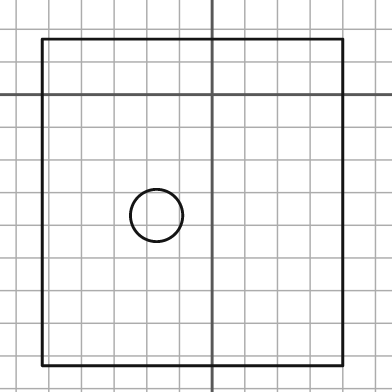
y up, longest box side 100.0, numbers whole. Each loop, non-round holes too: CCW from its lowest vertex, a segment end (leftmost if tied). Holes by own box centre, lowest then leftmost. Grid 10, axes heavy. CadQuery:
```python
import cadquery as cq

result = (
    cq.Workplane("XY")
    .moveTo(-52.0, -83.0)
    .lineTo(40.0, -83.0)
    .lineTo(40.0, 17.0)
    .lineTo(-52.0, 17.0)
    .close()
    .moveTo(-17.0, -37.0)
    .circle(8.0)
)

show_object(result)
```